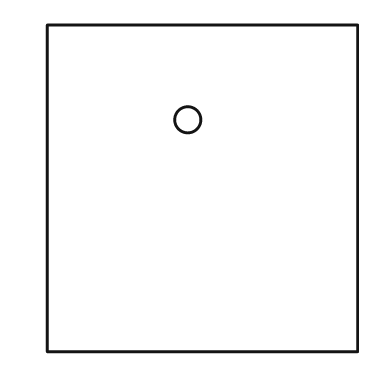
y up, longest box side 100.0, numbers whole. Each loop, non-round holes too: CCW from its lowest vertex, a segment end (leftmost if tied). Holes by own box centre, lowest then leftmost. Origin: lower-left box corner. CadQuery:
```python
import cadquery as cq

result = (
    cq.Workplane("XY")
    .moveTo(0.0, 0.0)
    .lineTo(95.0, 0.0)
    .lineTo(95.0, 100.0)
    .lineTo(0.0, 100.0)
    .close()
    .moveTo(43.0, 71.0)
    .circle(4.0)
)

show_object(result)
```